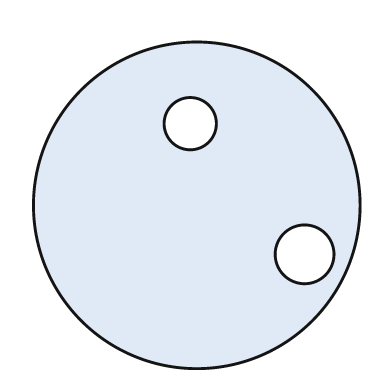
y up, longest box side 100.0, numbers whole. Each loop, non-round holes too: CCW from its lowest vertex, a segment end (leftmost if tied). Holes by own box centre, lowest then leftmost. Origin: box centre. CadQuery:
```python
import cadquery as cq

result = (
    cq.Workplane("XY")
    .moveTo(0.0, 0.0)
    .circle(50.0)
    .moveTo(33.0, -15.0)
    .circle(9.0)
    .moveTo(-2.0, 25.0)
    .circle(8.0)
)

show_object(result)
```